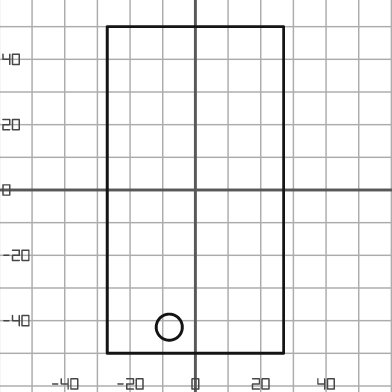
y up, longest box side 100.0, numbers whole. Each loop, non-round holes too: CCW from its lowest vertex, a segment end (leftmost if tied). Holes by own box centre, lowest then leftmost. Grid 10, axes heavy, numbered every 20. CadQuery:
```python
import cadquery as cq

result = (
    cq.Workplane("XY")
    .moveTo(-27.0, -50.0)
    .lineTo(27.0, -50.0)
    .lineTo(27.0, 50.0)
    .lineTo(-27.0, 50.0)
    .close()
    .moveTo(-8.0, -42.0)
    .circle(4.0)
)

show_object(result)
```